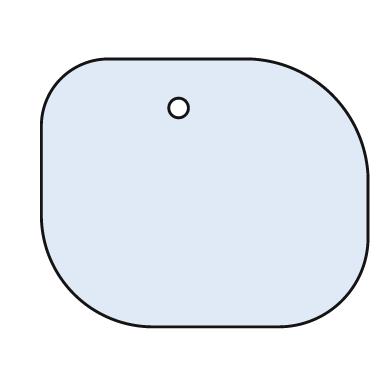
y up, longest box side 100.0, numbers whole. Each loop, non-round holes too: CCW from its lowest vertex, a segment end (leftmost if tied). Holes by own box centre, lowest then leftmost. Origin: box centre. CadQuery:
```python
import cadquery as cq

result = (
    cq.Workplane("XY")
    .moveTo(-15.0, -41.0)
    .lineTo(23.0, -41.0)
    .threePointArc((42.0, -33.0), (50.0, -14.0))
    .lineTo(50.0, 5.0)
    .threePointArc((39.0, 30.0), (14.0, 41.0))
    .lineTo(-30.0, 41.0)
    .threePointArc((-44.0, 35.0), (-50.0, 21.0))
    .lineTo(-50.0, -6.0)
    .threePointArc((-40.0, -31.0), (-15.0, -41.0))
    .close()
    .moveTo(-8.0, 26.0)
    .circle(3.0)
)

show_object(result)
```